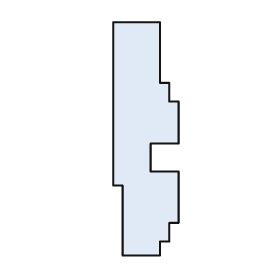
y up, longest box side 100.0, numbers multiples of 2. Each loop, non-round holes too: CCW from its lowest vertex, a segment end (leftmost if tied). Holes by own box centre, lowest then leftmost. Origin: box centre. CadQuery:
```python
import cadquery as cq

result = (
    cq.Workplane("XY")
    .moveTo(-10.0, -50.0)
    .lineTo(6.0, -50.0)
    .lineTo(6.0, -44.0)
    .lineTo(10.0, -44.0)
    .lineTo(10.0, -36.0)
    .lineTo(14.0, -36.0)
    .lineTo(14.0, -14.0)
    .lineTo(2.0, -14.0)
    .lineTo(2.0, -2.0)
    .lineTo(14.0, -2.0)
    .lineTo(14.0, 16.0)
    .lineTo(10.0, 16.0)
    .lineTo(10.0, 24.0)
    .lineTo(6.0, 24.0)
    .lineTo(6.0, 50.0)
    .lineTo(-14.0, 50.0)
    .lineTo(-14.0, -20.0)
    .lineTo(-10.0, -20.0)
    .close()
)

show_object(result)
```